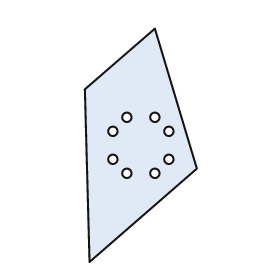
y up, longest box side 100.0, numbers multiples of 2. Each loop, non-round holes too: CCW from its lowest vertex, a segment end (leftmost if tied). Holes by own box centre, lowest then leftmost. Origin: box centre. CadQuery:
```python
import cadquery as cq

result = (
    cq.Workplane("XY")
    .moveTo(-22.0, -50.0)
    .lineTo(24.0, -10.0)
    .lineTo(6.0, 50.0)
    .lineTo(-24.0, 24.0)
    .close()
    .moveTo(-6.0, -12.0)
    .circle(2.0)
    .moveTo(6.0, -12.0)
    .circle(2.0)
    .moveTo(-12.0, -6.0)
    .circle(2.0)
    .moveTo(12.0, -6.0)
    .circle(2.0)
    .moveTo(-12.0, 6.0)
    .circle(2.0)
    .moveTo(12.0, 6.0)
    .circle(2.0)
    .moveTo(-6.0, 12.0)
    .circle(2.0)
    .moveTo(6.0, 12.0)
    .circle(2.0)
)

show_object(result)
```